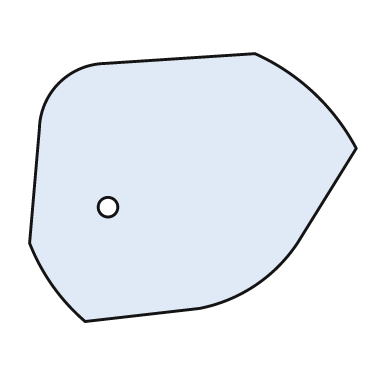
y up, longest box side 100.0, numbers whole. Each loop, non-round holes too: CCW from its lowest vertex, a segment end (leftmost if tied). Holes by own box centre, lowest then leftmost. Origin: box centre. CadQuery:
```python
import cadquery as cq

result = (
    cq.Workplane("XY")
    .moveTo(-33.0, -41.0)
    .lineTo(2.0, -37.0)
    .threePointArc((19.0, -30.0), (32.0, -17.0))
    .lineTo(50.0, 12.0)
    .threePointArc((37.0, 29.0), (19.0, 41.0))
    .lineTo(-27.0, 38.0)
    .threePointArc((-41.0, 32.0), (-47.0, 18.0))
    .lineTo(-50.0, -17.0)
    .threePointArc((-43.0, -30.0), (-33.0, -41.0))
    .close()
    .moveTo(-26.0, -6.0)
    .circle(3.0)
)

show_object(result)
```